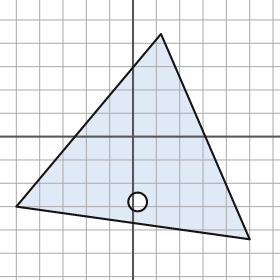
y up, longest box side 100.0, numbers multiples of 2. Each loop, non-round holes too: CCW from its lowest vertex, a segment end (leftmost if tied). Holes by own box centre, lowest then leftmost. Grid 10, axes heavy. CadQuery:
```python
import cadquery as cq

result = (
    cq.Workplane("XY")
    .moveTo(50.0, -44.0)
    .lineTo(12.0, 44.0)
    .lineTo(-50.0, -30.0)
    .close()
    .moveTo(2.0, -28.0)
    .circle(4.0)
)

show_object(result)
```